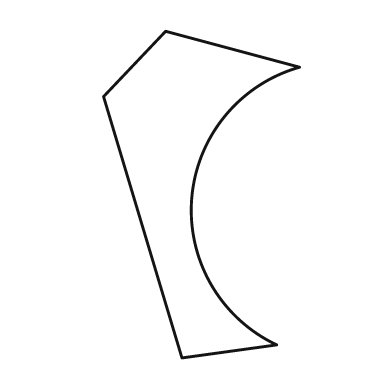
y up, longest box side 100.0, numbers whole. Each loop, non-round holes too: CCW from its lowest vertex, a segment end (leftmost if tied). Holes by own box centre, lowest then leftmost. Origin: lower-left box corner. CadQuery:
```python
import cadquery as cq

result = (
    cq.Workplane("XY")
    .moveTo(24.0, 0.0)
    .lineTo(53.0, 4.0)
    .threePointArc((27.0, 49.0), (60.0, 89.0))
    .lineTo(19.0, 100.0)
    .lineTo(0.0, 80.0)
    .close()
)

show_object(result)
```